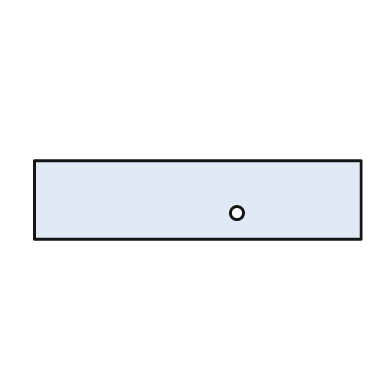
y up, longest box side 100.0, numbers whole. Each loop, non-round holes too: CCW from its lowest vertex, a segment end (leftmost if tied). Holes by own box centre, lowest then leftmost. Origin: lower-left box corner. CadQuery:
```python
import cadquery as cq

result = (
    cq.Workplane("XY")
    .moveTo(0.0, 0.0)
    .lineTo(100.0, 0.0)
    .lineTo(100.0, 24.0)
    .lineTo(0.0, 24.0)
    .close()
    .moveTo(62.0, 8.0)
    .circle(2.0)
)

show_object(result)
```